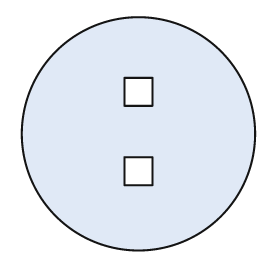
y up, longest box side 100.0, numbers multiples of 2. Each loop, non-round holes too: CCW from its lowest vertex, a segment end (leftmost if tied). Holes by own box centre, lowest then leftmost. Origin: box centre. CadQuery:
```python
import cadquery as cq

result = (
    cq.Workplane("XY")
    .moveTo(0.0, 0.0)
    .circle(50.0)
    .moveTo(-6.0, -22.0)
    .lineTo(6.0, -22.0)
    .lineTo(6.0, -10.0)
    .lineTo(-6.0, -10.0)
    .close()
    .moveTo(-6.0, 12.0)
    .lineTo(6.0, 12.0)
    .lineTo(6.0, 24.0)
    .lineTo(-6.0, 24.0)
    .close()
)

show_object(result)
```